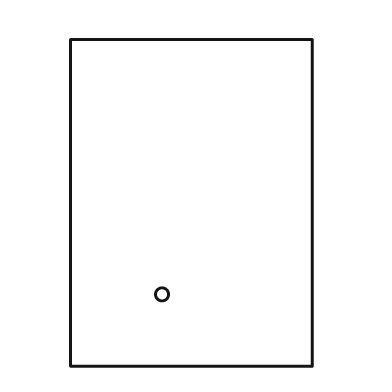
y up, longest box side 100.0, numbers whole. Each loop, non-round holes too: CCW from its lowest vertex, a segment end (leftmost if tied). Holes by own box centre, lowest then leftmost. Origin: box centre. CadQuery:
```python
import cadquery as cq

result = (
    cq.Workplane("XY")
    .moveTo(-37.0, -50.0)
    .lineTo(37.0, -50.0)
    .lineTo(37.0, 50.0)
    .lineTo(-37.0, 50.0)
    .close()
    .moveTo(-9.0, -28.0)
    .circle(2.0)
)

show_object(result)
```